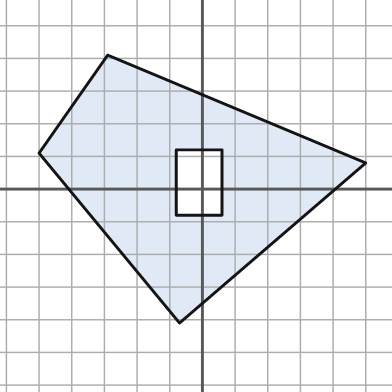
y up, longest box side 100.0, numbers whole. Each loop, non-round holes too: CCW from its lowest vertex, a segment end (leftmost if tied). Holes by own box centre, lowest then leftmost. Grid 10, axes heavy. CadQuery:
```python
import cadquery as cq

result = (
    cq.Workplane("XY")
    .moveTo(-7.0, -41.0)
    .lineTo(50.0, 8.0)
    .lineTo(-29.0, 41.0)
    .lineTo(-50.0, 11.0)
    .close()
    .moveTo(-8.0, -8.0)
    .lineTo(6.0, -8.0)
    .lineTo(6.0, 12.0)
    .lineTo(-8.0, 12.0)
    .close()
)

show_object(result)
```